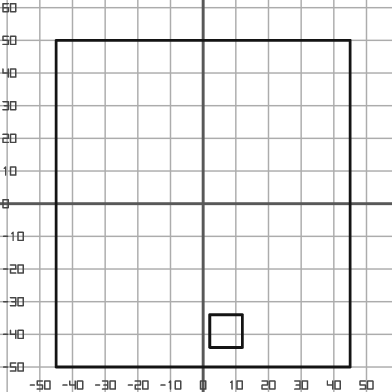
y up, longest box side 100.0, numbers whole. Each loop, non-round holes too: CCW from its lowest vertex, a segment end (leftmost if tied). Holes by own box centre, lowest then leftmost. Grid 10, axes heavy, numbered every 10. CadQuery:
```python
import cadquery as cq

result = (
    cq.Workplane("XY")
    .moveTo(-45.0, -50.0)
    .lineTo(45.0, -50.0)
    .lineTo(45.0, 50.0)
    .lineTo(-45.0, 50.0)
    .close()
    .moveTo(2.0, -44.0)
    .lineTo(12.0, -44.0)
    .lineTo(12.0, -34.0)
    .lineTo(2.0, -34.0)
    .close()
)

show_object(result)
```